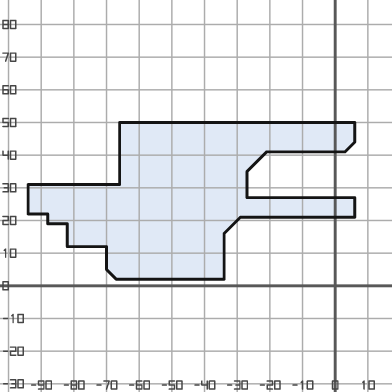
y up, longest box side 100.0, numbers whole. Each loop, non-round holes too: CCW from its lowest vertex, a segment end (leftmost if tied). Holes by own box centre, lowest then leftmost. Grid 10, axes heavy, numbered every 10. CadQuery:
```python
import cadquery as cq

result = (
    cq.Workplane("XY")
    .moveTo(-67.0, 2.0)
    .lineTo(-34.0, 2.0)
    .lineTo(-34.0, 16.0)
    .lineTo(-29.0, 21.0)
    .lineTo(6.0, 21.0)
    .lineTo(6.0, 27.0)
    .lineTo(-27.0, 27.0)
    .lineTo(-27.0, 35.0)
    .lineTo(-21.0, 41.0)
    .lineTo(3.0, 41.0)
    .lineTo(6.0, 44.0)
    .lineTo(6.0, 50.0)
    .lineTo(-66.0, 50.0)
    .lineTo(-66.0, 31.0)
    .lineTo(-94.0, 31.0)
    .lineTo(-94.0, 22.0)
    .lineTo(-88.0, 22.0)
    .lineTo(-88.0, 19.0)
    .lineTo(-82.0, 19.0)
    .lineTo(-82.0, 12.0)
    .lineTo(-70.0, 12.0)
    .lineTo(-70.0, 5.0)
    .close()
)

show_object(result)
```